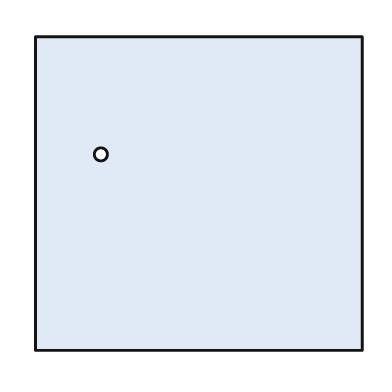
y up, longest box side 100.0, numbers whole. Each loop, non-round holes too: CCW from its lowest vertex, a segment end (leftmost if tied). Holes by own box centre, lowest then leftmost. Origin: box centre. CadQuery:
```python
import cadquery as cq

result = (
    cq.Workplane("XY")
    .moveTo(-50.0, -48.0)
    .lineTo(50.0, -48.0)
    .lineTo(50.0, 48.0)
    .lineTo(-50.0, 48.0)
    .close()
    .moveTo(-30.0, 12.0)
    .circle(2.0)
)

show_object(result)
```